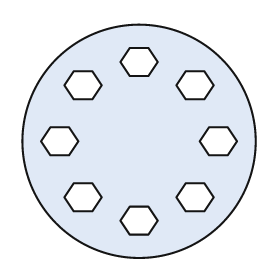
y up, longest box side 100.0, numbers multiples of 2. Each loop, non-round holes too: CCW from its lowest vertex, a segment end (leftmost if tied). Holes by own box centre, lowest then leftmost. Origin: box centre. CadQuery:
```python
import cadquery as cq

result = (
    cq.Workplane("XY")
    .moveTo(0.0, 0.0)
    .circle(50.0)
    .moveTo(-4.0, -40.0)
    .lineTo(4.0, -40.0)
    .lineTo(8.0, -34.0)
    .lineTo(4.0, -28.0)
    .lineTo(-4.0, -28.0)
    .lineTo(-8.0, -34.0)
    .close()
    .moveTo(-28.0, -30.0)
    .lineTo(-20.0, -30.0)
    .lineTo(-16.0, -24.0)
    .lineTo(-20.0, -18.0)
    .lineTo(-28.0, -18.0)
    .lineTo(-32.0, -24.0)
    .close()
    .moveTo(20.0, -30.0)
    .lineTo(28.0, -30.0)
    .lineTo(32.0, -24.0)
    .lineTo(28.0, -18.0)
    .lineTo(20.0, -18.0)
    .lineTo(16.0, -24.0)
    .close()
    .moveTo(-38.0, -6.0)
    .lineTo(-30.0, -6.0)
    .lineTo(-26.0, 0.0)
    .lineTo(-30.0, 6.0)
    .lineTo(-38.0, 6.0)
    .lineTo(-42.0, 0.0)
    .close()
    .moveTo(30.0, -6.0)
    .lineTo(38.0, -6.0)
    .lineTo(42.0, 0.0)
    .lineTo(38.0, 6.0)
    .lineTo(30.0, 6.0)
    .lineTo(26.0, 0.0)
    .close()
    .moveTo(-28.0, 18.0)
    .lineTo(-20.0, 18.0)
    .lineTo(-16.0, 24.0)
    .lineTo(-20.0, 30.0)
    .lineTo(-28.0, 30.0)
    .lineTo(-32.0, 24.0)
    .close()
    .moveTo(20.0, 18.0)
    .lineTo(28.0, 18.0)
    .lineTo(32.0, 24.0)
    .lineTo(28.0, 30.0)
    .lineTo(20.0, 30.0)
    .lineTo(16.0, 24.0)
    .close()
    .moveTo(-4.0, 28.0)
    .lineTo(4.0, 28.0)
    .lineTo(8.0, 34.0)
    .lineTo(4.0, 40.0)
    .lineTo(-4.0, 40.0)
    .lineTo(-8.0, 34.0)
    .close()
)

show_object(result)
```